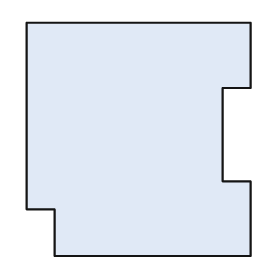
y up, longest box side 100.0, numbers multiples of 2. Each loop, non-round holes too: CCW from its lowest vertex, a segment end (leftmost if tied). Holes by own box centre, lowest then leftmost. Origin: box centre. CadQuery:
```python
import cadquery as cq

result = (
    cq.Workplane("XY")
    .moveTo(-36.0, -50.0)
    .lineTo(48.0, -50.0)
    .lineTo(48.0, -18.0)
    .lineTo(36.0, -18.0)
    .lineTo(36.0, 22.0)
    .lineTo(48.0, 22.0)
    .lineTo(48.0, 50.0)
    .lineTo(-48.0, 50.0)
    .lineTo(-48.0, -30.0)
    .lineTo(-36.0, -30.0)
    .close()
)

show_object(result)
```